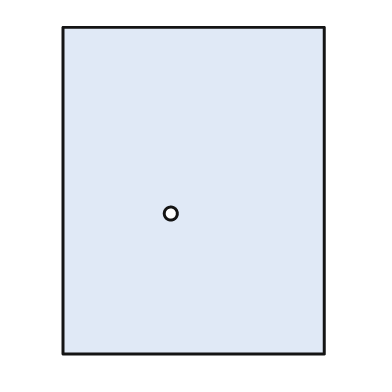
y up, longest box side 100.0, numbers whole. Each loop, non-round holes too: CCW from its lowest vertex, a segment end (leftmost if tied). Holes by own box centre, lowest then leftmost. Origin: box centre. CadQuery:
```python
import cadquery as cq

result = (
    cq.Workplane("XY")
    .moveTo(-40.0, -50.0)
    .lineTo(40.0, -50.0)
    .lineTo(40.0, 50.0)
    .lineTo(-40.0, 50.0)
    .close()
    .moveTo(-7.0, -7.0)
    .circle(2.0)
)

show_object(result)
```